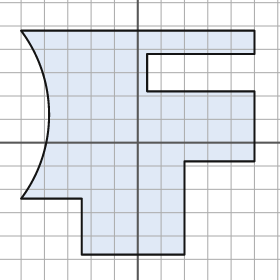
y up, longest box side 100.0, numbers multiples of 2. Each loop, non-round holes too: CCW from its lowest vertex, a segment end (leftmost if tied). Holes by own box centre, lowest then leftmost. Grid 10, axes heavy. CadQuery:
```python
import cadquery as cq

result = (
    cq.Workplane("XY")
    .moveTo(-24.0, -48.0)
    .lineTo(20.0, -48.0)
    .lineTo(20.0, -8.0)
    .lineTo(50.0, -8.0)
    .lineTo(50.0, 22.0)
    .lineTo(4.0, 22.0)
    .lineTo(4.0, 38.0)
    .lineTo(50.0, 38.0)
    .lineTo(50.0, 48.0)
    .lineTo(-50.0, 48.0)
    .threePointArc((-38.0, 12.0), (-50.0, -24.0))
    .lineTo(-24.0, -24.0)
    .close()
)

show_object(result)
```